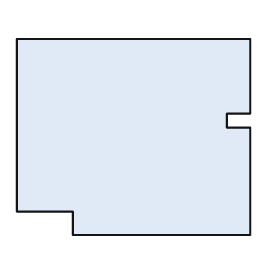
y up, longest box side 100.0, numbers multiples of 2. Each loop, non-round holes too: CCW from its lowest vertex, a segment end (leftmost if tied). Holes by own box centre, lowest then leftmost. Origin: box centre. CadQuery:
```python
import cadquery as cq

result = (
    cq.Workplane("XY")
    .moveTo(-26.0, -42.0)
    .lineTo(50.0, -42.0)
    .lineTo(50.0, 4.0)
    .lineTo(40.0, 4.0)
    .lineTo(40.0, 10.0)
    .lineTo(50.0, 10.0)
    .lineTo(50.0, 42.0)
    .lineTo(-50.0, 42.0)
    .lineTo(-50.0, -32.0)
    .lineTo(-26.0, -32.0)
    .close()
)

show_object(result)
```